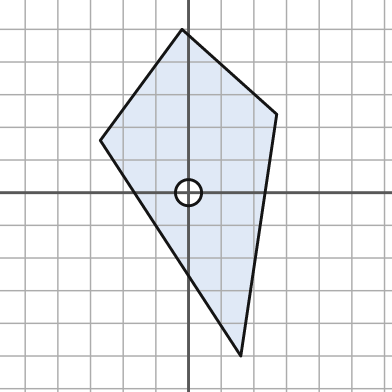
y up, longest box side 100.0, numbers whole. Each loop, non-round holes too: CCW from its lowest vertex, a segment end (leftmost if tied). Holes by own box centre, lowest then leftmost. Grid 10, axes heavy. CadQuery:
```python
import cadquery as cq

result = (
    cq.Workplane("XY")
    .moveTo(16.0, -50.0)
    .lineTo(27.0, 24.0)
    .lineTo(-2.0, 50.0)
    .lineTo(-27.0, 16.0)
    .close()
    .moveTo(0.0, 0.0)
    .circle(4.0)
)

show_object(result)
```